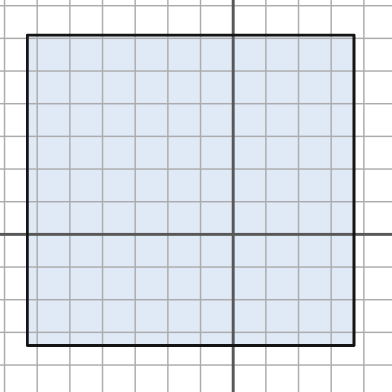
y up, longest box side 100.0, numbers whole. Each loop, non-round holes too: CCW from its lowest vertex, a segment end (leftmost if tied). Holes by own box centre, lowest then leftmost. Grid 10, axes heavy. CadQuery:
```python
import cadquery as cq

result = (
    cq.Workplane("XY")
    .moveTo(-63.0, -34.0)
    .lineTo(37.0, -34.0)
    .lineTo(37.0, 61.0)
    .lineTo(-63.0, 61.0)
    .close()
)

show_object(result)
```